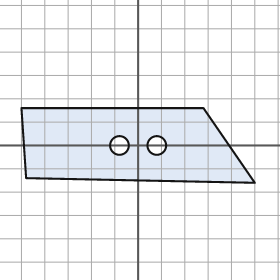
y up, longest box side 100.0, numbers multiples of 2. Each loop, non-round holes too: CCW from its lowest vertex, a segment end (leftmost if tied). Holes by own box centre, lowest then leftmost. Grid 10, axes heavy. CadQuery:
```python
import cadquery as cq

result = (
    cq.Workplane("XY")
    .moveTo(50.0, -16.0)
    .lineTo(28.0, 16.0)
    .lineTo(-50.0, 16.0)
    .lineTo(-48.0, -14.0)
    .close()
    .moveTo(-8.0, 0.0)
    .circle(4.0)
    .moveTo(8.0, 0.0)
    .circle(4.0)
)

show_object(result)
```